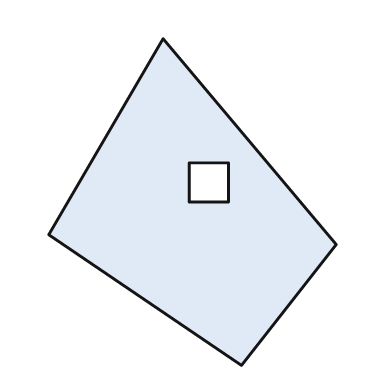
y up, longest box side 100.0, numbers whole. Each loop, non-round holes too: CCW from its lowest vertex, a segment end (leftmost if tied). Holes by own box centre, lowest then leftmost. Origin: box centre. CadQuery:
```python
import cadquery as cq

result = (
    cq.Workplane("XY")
    .moveTo(15.0, -50.0)
    .lineTo(44.0, -13.0)
    .lineTo(-9.0, 50.0)
    .lineTo(-44.0, -10.0)
    .close()
    .moveTo(-1.0, 0.0)
    .lineTo(11.0, 0.0)
    .lineTo(11.0, 12.0)
    .lineTo(-1.0, 12.0)
    .close()
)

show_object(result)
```